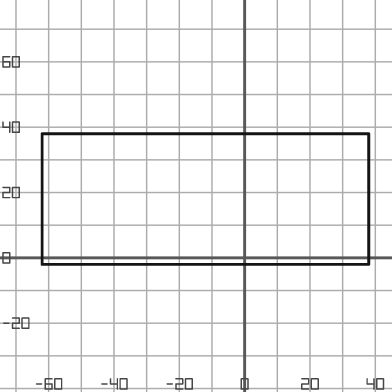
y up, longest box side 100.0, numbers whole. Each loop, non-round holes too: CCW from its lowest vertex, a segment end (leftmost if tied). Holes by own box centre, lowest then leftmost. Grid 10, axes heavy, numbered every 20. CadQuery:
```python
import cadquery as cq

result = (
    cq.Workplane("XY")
    .moveTo(-62.0, -2.0)
    .lineTo(38.0, -2.0)
    .lineTo(38.0, 38.0)
    .lineTo(-62.0, 38.0)
    .close()
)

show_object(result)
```